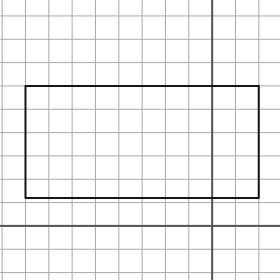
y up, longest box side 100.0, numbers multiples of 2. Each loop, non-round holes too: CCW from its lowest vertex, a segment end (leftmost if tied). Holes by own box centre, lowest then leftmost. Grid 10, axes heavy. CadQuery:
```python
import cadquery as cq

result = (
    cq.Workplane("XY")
    .moveTo(-80.0, 12.0)
    .lineTo(20.0, 12.0)
    .lineTo(20.0, 60.0)
    .lineTo(-80.0, 60.0)
    .close()
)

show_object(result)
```